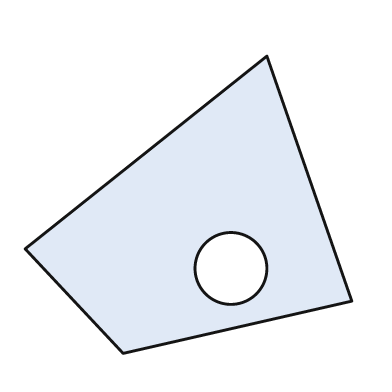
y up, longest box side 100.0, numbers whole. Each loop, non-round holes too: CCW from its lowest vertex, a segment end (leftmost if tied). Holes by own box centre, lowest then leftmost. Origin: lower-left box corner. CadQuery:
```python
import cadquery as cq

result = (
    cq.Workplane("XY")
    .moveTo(30.0, 0.0)
    .lineTo(100.0, 16.0)
    .lineTo(74.0, 91.0)
    .lineTo(0.0, 32.0)
    .close()
    .moveTo(63.0, 26.0)
    .circle(11.0)
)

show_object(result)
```